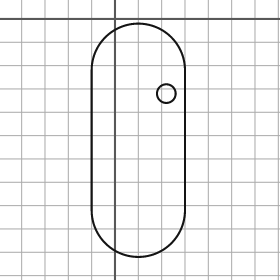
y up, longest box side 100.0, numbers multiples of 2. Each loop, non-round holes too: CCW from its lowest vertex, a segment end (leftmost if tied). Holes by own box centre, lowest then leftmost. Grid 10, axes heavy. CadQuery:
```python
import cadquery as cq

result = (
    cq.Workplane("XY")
    .moveTo(-10.0, -82.0)
    .threePointArc((10.0, -102.0), (30.0, -82.0))
    .lineTo(30.0, -22.0)
    .threePointArc((10.0, -2.0), (-10.0, -22.0))
    .close()
    .moveTo(22.0, -32.0)
    .circle(4.0)
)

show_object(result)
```